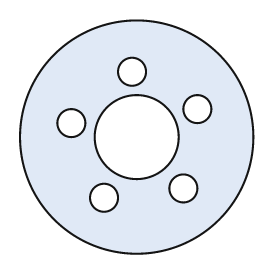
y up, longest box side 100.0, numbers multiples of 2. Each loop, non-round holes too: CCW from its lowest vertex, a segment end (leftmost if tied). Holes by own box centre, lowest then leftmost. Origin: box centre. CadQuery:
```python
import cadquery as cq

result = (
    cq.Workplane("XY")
    .moveTo(0.0, 0.0)
    .circle(50.0)
    .moveTo(-14.0, -26.0)
    .circle(6.0)
    .moveTo(20.0, -22.0)
    .circle(6.0)
    .moveTo(0.0, 0.0)
    .circle(18.0)
    .moveTo(-28.0, 6.0)
    .circle(6.0)
    .moveTo(26.0, 12.0)
    .circle(6.0)
    .moveTo(-2.0, 28.0)
    .circle(6.0)
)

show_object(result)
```